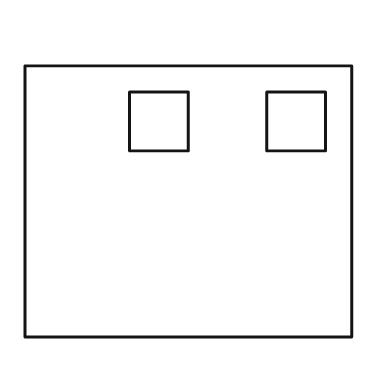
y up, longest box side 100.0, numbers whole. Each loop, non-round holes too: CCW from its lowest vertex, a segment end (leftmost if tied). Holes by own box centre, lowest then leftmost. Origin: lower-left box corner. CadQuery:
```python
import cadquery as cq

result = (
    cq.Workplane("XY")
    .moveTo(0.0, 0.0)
    .lineTo(100.0, 0.0)
    .lineTo(100.0, 83.0)
    .lineTo(0.0, 83.0)
    .close()
    .moveTo(32.0, 57.0)
    .lineTo(50.0, 57.0)
    .lineTo(50.0, 75.0)
    .lineTo(32.0, 75.0)
    .close()
    .moveTo(74.0, 57.0)
    .lineTo(92.0, 57.0)
    .lineTo(92.0, 75.0)
    .lineTo(74.0, 75.0)
    .close()
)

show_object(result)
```